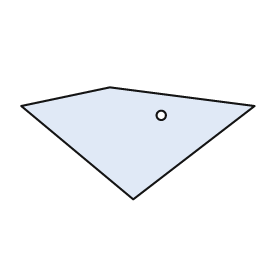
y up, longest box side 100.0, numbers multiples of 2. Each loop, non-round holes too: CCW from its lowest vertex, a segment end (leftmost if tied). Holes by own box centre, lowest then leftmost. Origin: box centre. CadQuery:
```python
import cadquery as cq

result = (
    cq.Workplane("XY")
    .moveTo(-2.0, -24.0)
    .lineTo(50.0, 16.0)
    .lineTo(-12.0, 24.0)
    .lineTo(-50.0, 16.0)
    .close()
    .moveTo(10.0, 12.0)
    .circle(2.0)
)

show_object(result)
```